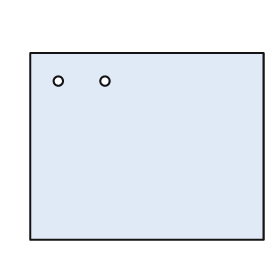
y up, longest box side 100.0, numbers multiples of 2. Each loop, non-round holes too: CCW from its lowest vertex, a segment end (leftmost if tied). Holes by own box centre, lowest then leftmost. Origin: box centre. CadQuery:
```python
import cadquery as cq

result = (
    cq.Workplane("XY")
    .moveTo(-50.0, -40.0)
    .lineTo(50.0, -40.0)
    .lineTo(50.0, 40.0)
    .lineTo(-50.0, 40.0)
    .close()
    .moveTo(-38.0, 28.0)
    .circle(2.0)
    .moveTo(-18.0, 28.0)
    .circle(2.0)
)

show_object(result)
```